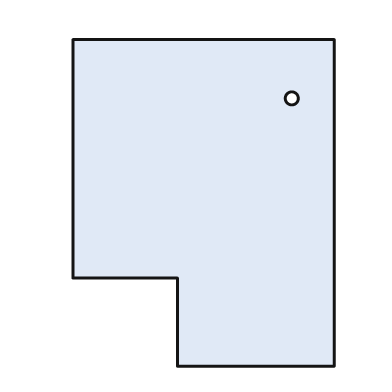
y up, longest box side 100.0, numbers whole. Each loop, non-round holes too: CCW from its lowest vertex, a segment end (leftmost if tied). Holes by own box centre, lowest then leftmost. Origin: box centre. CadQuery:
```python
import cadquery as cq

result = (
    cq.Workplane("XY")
    .moveTo(-8.0, -50.0)
    .lineTo(40.0, -50.0)
    .lineTo(40.0, 50.0)
    .lineTo(-40.0, 50.0)
    .lineTo(-40.0, -23.0)
    .lineTo(-8.0, -23.0)
    .close()
    .moveTo(27.0, 32.0)
    .circle(2.0)
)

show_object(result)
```